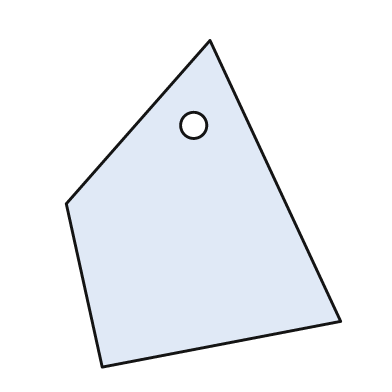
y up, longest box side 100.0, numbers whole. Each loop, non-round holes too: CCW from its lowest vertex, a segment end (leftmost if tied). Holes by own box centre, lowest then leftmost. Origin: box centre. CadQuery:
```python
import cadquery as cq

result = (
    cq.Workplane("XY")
    .moveTo(-31.0, -50.0)
    .lineTo(42.0, -36.0)
    .lineTo(2.0, 50.0)
    .lineTo(-42.0, 0.0)
    .close()
    .moveTo(-3.0, 24.0)
    .circle(4.0)
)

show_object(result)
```